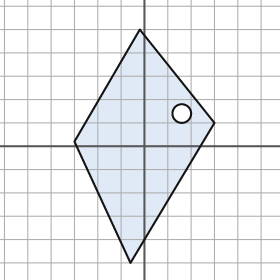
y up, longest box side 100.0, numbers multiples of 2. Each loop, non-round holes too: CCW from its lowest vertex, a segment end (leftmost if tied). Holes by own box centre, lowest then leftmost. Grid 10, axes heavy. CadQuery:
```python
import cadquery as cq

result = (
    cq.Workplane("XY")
    .moveTo(-6.0, -50.0)
    .lineTo(30.0, 10.0)
    .lineTo(-2.0, 50.0)
    .lineTo(-30.0, 2.0)
    .close()
    .moveTo(16.0, 14.0)
    .circle(4.0)
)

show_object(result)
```